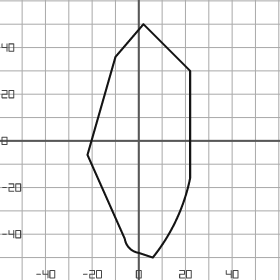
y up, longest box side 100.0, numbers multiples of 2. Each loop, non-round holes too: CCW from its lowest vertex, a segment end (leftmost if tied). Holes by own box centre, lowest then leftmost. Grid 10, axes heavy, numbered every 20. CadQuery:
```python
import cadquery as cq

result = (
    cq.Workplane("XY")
    .moveTo(6.0, -50.0)
    .threePointArc((16.0, -34.0), (22.0, -16.0))
    .lineTo(22.0, 30.0)
    .lineTo(2.0, 50.0)
    .lineTo(-10.0, 36.0)
    .lineTo(-22.0, -6.0)
    .lineTo(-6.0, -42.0)
    .threePointArc((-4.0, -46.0), (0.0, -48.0))
    .close()
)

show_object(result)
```